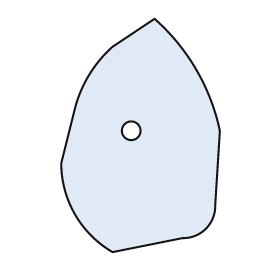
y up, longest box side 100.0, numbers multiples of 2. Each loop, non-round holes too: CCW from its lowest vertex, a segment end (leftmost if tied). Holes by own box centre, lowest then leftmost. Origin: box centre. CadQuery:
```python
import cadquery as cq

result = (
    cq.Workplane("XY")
    .moveTo(-12.0, -50.0)
    .lineTo(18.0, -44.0)
    .threePointArc((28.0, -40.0), (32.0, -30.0))
    .lineTo(34.0, 2.0)
    .threePointArc((24.0, 28.0), (6.0, 50.0))
    .lineTo(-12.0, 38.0)
    .threePointArc((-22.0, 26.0), (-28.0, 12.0))
    .lineTo(-34.0, -12.0)
    .threePointArc((-28.0, -34.0), (-12.0, -50.0))
    .close()
    .moveTo(-4.0, 2.0)
    .circle(4.0)
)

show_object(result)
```